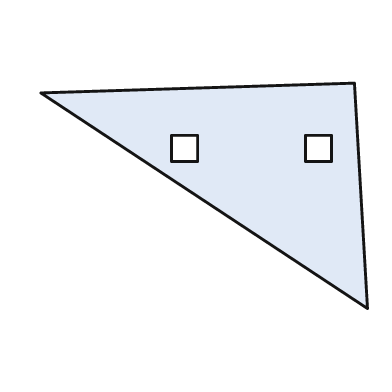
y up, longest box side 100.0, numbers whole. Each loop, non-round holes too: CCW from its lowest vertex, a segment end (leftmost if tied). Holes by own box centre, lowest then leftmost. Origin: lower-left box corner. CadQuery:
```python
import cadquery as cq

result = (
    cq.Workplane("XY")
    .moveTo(100.0, 0.0)
    .lineTo(96.0, 69.0)
    .lineTo(0.0, 66.0)
    .close()
    .moveTo(40.0, 45.0)
    .lineTo(48.0, 45.0)
    .lineTo(48.0, 53.0)
    .lineTo(40.0, 53.0)
    .close()
    .moveTo(81.0, 45.0)
    .lineTo(89.0, 45.0)
    .lineTo(89.0, 53.0)
    .lineTo(81.0, 53.0)
    .close()
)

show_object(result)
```